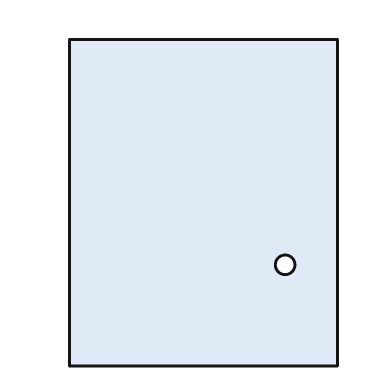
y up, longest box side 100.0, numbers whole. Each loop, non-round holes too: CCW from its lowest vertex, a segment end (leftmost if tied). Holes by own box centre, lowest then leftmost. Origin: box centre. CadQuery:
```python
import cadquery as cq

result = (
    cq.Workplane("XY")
    .moveTo(-41.0, -50.0)
    .lineTo(41.0, -50.0)
    .lineTo(41.0, 50.0)
    .lineTo(-41.0, 50.0)
    .close()
    .moveTo(25.0, -19.0)
    .circle(3.0)
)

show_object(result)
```